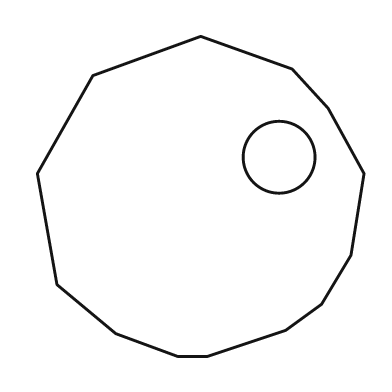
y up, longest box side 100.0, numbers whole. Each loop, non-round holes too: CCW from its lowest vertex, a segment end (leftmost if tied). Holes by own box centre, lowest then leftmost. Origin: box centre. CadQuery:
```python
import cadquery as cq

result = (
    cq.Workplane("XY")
    .moveTo(-7.0, -49.0)
    .lineTo(2.0, -49.0)
    .lineTo(26.0, -41.0)
    .lineTo(37.0, -33.0)
    .lineTo(46.0, -18.0)
    .lineTo(50.0, 7.0)
    .lineTo(39.0, 27.0)
    .lineTo(28.0, 39.0)
    .lineTo(0.0, 49.0)
    .lineTo(-33.0, 37.0)
    .lineTo(-50.0, 7.0)
    .lineTo(-44.0, -27.0)
    .lineTo(-26.0, -42.0)
    .close()
    .moveTo(24.0, 12.0)
    .circle(11.0)
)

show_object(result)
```